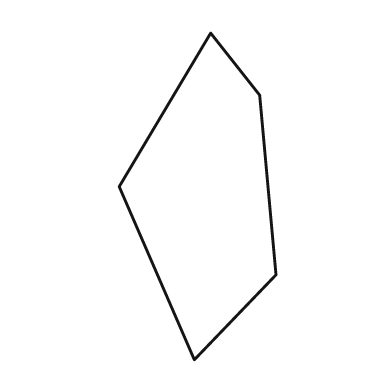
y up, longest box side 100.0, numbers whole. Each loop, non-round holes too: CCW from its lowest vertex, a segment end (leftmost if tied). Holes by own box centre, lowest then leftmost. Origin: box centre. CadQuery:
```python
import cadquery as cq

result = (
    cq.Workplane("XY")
    .moveTo(-1.0, -50.0)
    .lineTo(24.0, -24.0)
    .lineTo(19.0, 31.0)
    .lineTo(4.0, 50.0)
    .lineTo(-24.0, 3.0)
    .close()
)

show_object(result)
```